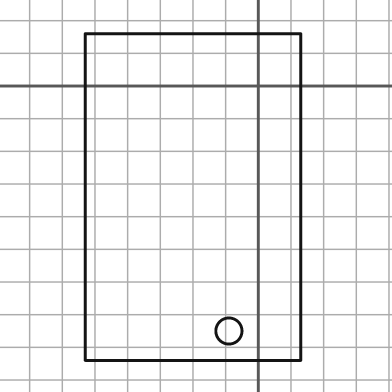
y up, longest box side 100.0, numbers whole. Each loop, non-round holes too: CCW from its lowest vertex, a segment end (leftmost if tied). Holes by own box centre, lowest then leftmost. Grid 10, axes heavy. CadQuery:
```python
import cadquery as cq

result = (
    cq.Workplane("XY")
    .moveTo(-53.0, -84.0)
    .lineTo(13.0, -84.0)
    .lineTo(13.0, 16.0)
    .lineTo(-53.0, 16.0)
    .close()
    .moveTo(-9.0, -75.0)
    .circle(4.0)
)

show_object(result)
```